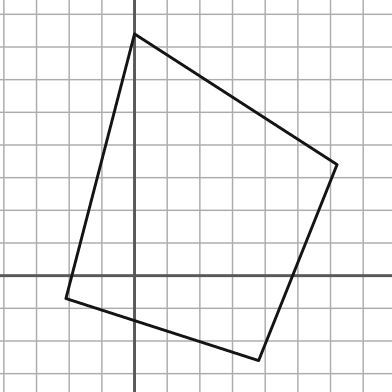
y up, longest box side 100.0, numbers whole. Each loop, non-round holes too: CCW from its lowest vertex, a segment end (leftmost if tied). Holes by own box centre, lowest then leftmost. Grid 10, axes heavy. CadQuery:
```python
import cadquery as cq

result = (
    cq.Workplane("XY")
    .moveTo(38.0, -26.0)
    .lineTo(62.0, 34.0)
    .lineTo(0.0, 74.0)
    .lineTo(-21.0, -7.0)
    .close()
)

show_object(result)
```